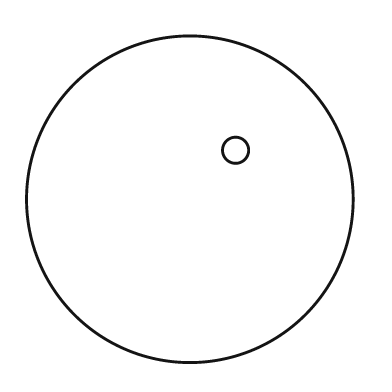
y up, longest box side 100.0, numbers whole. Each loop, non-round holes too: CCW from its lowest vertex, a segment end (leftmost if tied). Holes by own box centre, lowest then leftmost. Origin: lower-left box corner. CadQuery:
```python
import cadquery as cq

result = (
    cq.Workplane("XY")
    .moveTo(50.0, 50.0)
    .circle(50.0)
    .moveTo(64.0, 65.0)
    .circle(4.0)
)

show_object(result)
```